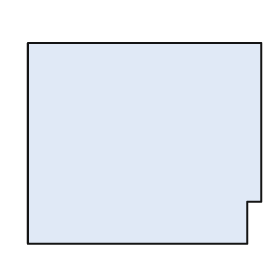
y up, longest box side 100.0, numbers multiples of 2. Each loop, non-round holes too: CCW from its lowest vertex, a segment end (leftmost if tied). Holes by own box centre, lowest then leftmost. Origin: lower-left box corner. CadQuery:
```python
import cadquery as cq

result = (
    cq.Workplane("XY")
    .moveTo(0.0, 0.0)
    .lineTo(94.0, 0.0)
    .lineTo(94.0, 18.0)
    .lineTo(100.0, 18.0)
    .lineTo(100.0, 86.0)
    .lineTo(0.0, 86.0)
    .close()
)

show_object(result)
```